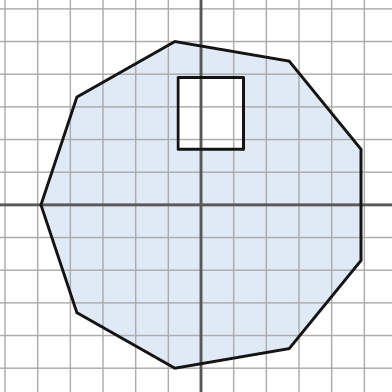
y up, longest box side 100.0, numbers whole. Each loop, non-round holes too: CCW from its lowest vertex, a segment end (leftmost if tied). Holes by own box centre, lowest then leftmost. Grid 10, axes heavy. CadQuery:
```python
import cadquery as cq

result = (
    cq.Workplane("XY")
    .moveTo(-8.0, -50.0)
    .lineTo(27.0, -44.0)
    .lineTo(49.0, -17.0)
    .lineTo(49.0, 17.0)
    .lineTo(27.0, 44.0)
    .lineTo(-8.0, 50.0)
    .lineTo(-38.0, 33.0)
    .lineTo(-49.0, 0.0)
    .lineTo(-38.0, -33.0)
    .close()
    .moveTo(-7.0, 17.0)
    .lineTo(13.0, 17.0)
    .lineTo(13.0, 39.0)
    .lineTo(-7.0, 39.0)
    .close()
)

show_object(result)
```